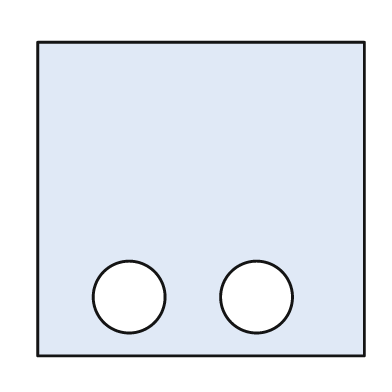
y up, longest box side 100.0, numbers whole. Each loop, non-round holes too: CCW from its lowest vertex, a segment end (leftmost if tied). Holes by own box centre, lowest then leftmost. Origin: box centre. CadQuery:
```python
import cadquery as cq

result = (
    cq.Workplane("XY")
    .moveTo(-50.0, -48.0)
    .lineTo(50.0, -48.0)
    .lineTo(50.0, 48.0)
    .lineTo(-50.0, 48.0)
    .close()
    .moveTo(-22.0, -30.0)
    .circle(11.0)
    .moveTo(17.0, -30.0)
    .circle(11.0)
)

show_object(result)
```